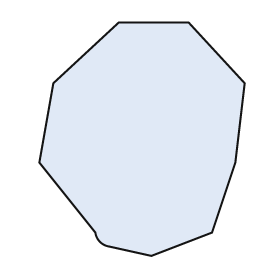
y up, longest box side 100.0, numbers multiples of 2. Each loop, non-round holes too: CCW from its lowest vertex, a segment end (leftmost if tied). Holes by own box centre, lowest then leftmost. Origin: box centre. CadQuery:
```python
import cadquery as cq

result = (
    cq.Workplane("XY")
    .moveTo(4.0, -50.0)
    .lineTo(30.0, -40.0)
    .lineTo(40.0, -10.0)
    .lineTo(44.0, 24.0)
    .lineTo(20.0, 50.0)
    .lineTo(-10.0, 50.0)
    .lineTo(-38.0, 24.0)
    .lineTo(-44.0, -10.0)
    .lineTo(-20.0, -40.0)
    .threePointArc((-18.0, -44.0), (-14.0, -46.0))
    .close()
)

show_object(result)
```